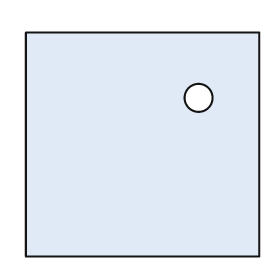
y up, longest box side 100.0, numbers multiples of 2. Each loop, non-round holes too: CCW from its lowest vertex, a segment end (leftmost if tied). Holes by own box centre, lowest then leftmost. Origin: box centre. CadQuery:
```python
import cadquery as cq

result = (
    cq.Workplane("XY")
    .moveTo(-50.0, -48.0)
    .lineTo(50.0, -48.0)
    .lineTo(50.0, 48.0)
    .lineTo(-50.0, 48.0)
    .close()
    .moveTo(24.0, 20.0)
    .circle(6.0)
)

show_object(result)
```